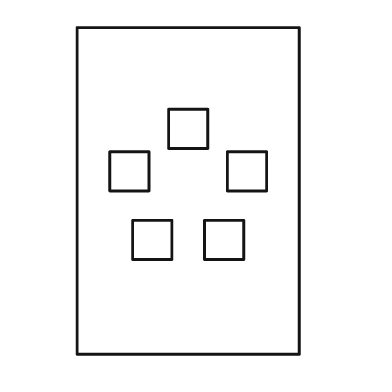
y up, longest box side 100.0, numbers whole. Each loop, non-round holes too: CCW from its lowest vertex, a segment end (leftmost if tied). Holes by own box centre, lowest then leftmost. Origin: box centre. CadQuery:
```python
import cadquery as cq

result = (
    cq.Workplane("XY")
    .moveTo(-34.0, -50.0)
    .lineTo(34.0, -50.0)
    .lineTo(34.0, 50.0)
    .lineTo(-34.0, 50.0)
    .close()
    .moveTo(-17.0, -21.0)
    .lineTo(-5.0, -21.0)
    .lineTo(-5.0, -9.0)
    .lineTo(-17.0, -9.0)
    .close()
    .moveTo(5.0, -21.0)
    .lineTo(17.0, -21.0)
    .lineTo(17.0, -9.0)
    .lineTo(5.0, -9.0)
    .close()
    .moveTo(-24.0, 0.0)
    .lineTo(-12.0, 0.0)
    .lineTo(-12.0, 12.0)
    .lineTo(-24.0, 12.0)
    .close()
    .moveTo(12.0, 0.0)
    .lineTo(24.0, 0.0)
    .lineTo(24.0, 12.0)
    .lineTo(12.0, 12.0)
    .close()
    .moveTo(-6.0, 13.0)
    .lineTo(6.0, 13.0)
    .lineTo(6.0, 25.0)
    .lineTo(-6.0, 25.0)
    .close()
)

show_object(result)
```